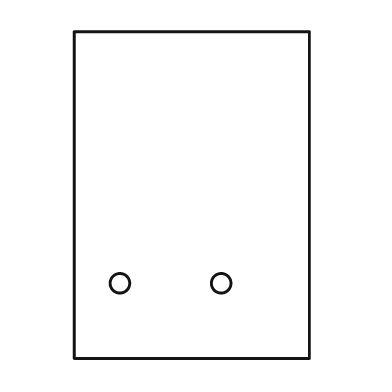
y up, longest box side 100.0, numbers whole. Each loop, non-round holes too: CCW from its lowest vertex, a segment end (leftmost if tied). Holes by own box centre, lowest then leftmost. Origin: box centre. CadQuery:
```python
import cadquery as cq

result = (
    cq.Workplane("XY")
    .moveTo(-36.0, -50.0)
    .lineTo(36.0, -50.0)
    .lineTo(36.0, 50.0)
    .lineTo(-36.0, 50.0)
    .close()
    .moveTo(-22.0, -27.0)
    .circle(3.0)
    .moveTo(9.0, -27.0)
    .circle(3.0)
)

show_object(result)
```